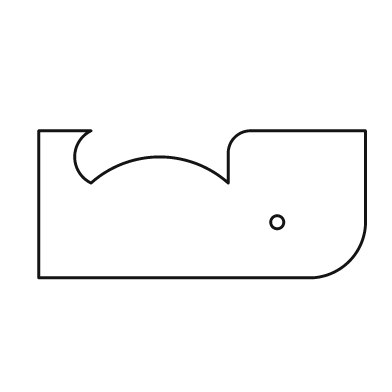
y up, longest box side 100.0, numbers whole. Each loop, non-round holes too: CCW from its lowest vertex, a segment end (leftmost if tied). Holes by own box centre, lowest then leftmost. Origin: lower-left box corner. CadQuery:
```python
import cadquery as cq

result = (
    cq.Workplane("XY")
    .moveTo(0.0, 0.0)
    .lineTo(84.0, 0.0)
    .threePointArc((95.0, 5.0), (100.0, 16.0))
    .lineTo(100.0, 45.0)
    .lineTo(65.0, 45.0)
    .threePointArc((60.0, 43.0), (58.0, 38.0))
    .lineTo(58.0, 29.0)
    .threePointArc((37.0, 37.0), (16.0, 29.0))
    .threePointArc((11.0, 37.0), (16.0, 45.0))
    .lineTo(0.0, 45.0)
    .close()
    .moveTo(73.0, 17.0)
    .circle(2.0)
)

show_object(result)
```